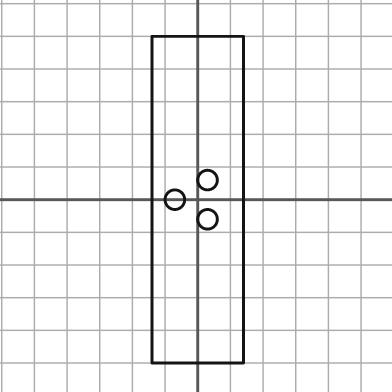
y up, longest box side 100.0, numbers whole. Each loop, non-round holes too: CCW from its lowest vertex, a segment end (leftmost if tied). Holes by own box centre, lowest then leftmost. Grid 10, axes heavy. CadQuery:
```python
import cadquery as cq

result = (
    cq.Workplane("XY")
    .moveTo(-14.0, -50.0)
    .lineTo(14.0, -50.0)
    .lineTo(14.0, 50.0)
    .lineTo(-14.0, 50.0)
    .close()
    .moveTo(3.0, -6.0)
    .circle(3.0)
    .moveTo(-7.0, 0.0)
    .circle(3.0)
    .moveTo(3.0, 6.0)
    .circle(3.0)
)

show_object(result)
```